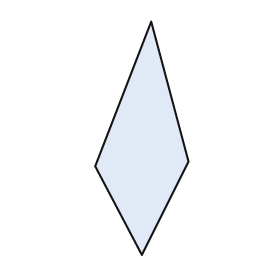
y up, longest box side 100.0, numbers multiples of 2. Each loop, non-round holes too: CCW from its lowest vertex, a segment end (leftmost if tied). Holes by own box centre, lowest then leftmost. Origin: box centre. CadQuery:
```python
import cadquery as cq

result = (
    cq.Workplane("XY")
    .moveTo(0.0, -50.0)
    .lineTo(20.0, -10.0)
    .lineTo(4.0, 50.0)
    .lineTo(-20.0, -12.0)
    .close()
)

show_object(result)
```